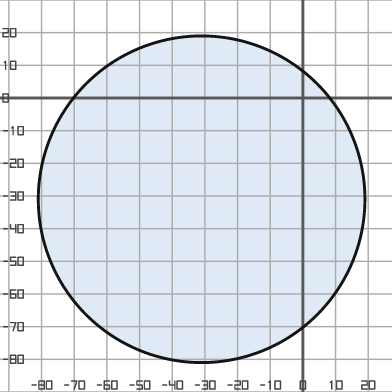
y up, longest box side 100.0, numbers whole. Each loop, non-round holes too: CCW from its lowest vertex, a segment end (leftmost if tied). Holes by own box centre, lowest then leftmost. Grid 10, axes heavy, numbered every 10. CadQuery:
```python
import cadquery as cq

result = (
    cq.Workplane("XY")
    .moveTo(-31.0, -31.0)
    .circle(50.0)
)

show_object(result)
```